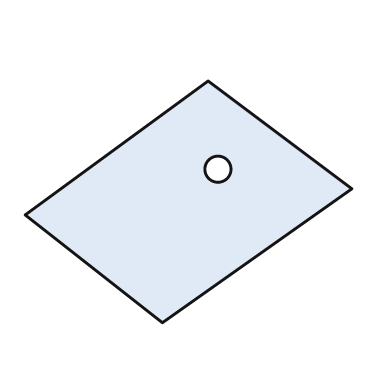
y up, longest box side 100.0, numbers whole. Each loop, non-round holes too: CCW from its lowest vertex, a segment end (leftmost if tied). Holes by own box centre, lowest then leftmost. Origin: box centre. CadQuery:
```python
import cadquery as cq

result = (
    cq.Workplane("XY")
    .moveTo(-8.0, -37.0)
    .lineTo(50.0, 4.0)
    .lineTo(6.0, 37.0)
    .lineTo(-50.0, -4.0)
    .close()
    .moveTo(9.0, 10.0)
    .circle(4.0)
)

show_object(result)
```